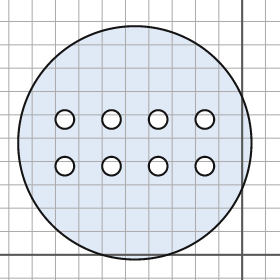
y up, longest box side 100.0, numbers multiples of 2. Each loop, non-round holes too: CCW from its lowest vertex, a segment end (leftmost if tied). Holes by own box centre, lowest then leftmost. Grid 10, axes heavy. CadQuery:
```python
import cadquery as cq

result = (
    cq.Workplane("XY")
    .moveTo(-46.0, 48.0)
    .circle(50.0)
    .moveTo(-76.0, 38.0)
    .circle(4.0)
    .moveTo(-56.0, 38.0)
    .circle(4.0)
    .moveTo(-36.0, 38.0)
    .circle(4.0)
    .moveTo(-16.0, 38.0)
    .circle(4.0)
    .moveTo(-76.0, 58.0)
    .circle(4.0)
    .moveTo(-56.0, 58.0)
    .circle(4.0)
    .moveTo(-36.0, 58.0)
    .circle(4.0)
    .moveTo(-16.0, 58.0)
    .circle(4.0)
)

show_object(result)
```